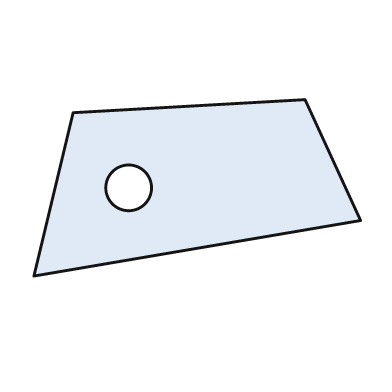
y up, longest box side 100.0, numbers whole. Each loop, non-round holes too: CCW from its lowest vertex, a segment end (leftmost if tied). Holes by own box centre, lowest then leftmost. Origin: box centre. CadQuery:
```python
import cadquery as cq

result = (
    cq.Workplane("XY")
    .moveTo(-50.0, -27.0)
    .lineTo(50.0, -10.0)
    .lineTo(33.0, 27.0)
    .lineTo(-38.0, 23.0)
    .close()
    .moveTo(-21.0, 0.0)
    .circle(7.0)
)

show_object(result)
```